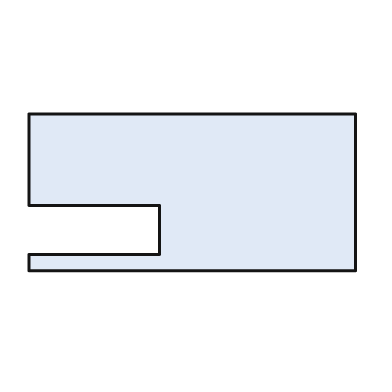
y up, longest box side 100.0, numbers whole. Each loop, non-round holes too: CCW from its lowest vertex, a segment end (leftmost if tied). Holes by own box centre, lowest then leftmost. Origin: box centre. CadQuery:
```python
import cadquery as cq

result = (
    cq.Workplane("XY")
    .moveTo(-50.0, -24.0)
    .lineTo(50.0, -24.0)
    .lineTo(50.0, 24.0)
    .lineTo(-50.0, 24.0)
    .lineTo(-50.0, -4.0)
    .lineTo(-10.0, -4.0)
    .lineTo(-10.0, -19.0)
    .lineTo(-50.0, -19.0)
    .close()
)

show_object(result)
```